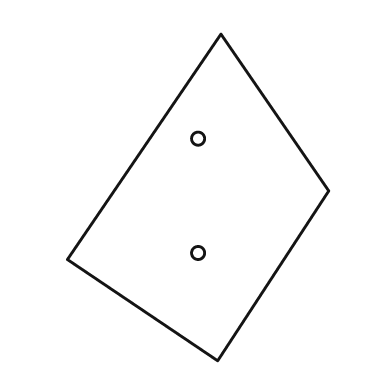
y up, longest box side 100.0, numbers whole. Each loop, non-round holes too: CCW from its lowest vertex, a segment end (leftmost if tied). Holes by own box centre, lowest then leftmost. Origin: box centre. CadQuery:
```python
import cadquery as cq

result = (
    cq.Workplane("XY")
    .moveTo(6.0, -50.0)
    .lineTo(40.0, 2.0)
    .lineTo(7.0, 50.0)
    .lineTo(-40.0, -19.0)
    .close()
    .moveTo(0.0, -17.0)
    .circle(2.0)
    .moveTo(0.0, 18.0)
    .circle(2.0)
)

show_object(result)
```